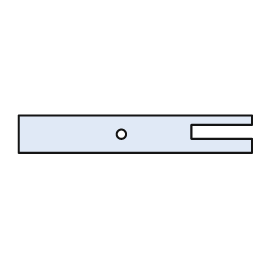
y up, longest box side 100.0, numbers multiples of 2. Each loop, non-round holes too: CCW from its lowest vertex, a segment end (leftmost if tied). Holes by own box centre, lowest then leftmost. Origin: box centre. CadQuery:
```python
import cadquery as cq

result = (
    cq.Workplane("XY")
    .moveTo(-50.0, -8.0)
    .lineTo(50.0, -8.0)
    .lineTo(50.0, -2.0)
    .lineTo(24.0, -2.0)
    .lineTo(24.0, 4.0)
    .lineTo(50.0, 4.0)
    .lineTo(50.0, 8.0)
    .lineTo(-50.0, 8.0)
    .close()
    .moveTo(-6.0, 0.0)
    .circle(2.0)
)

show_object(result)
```